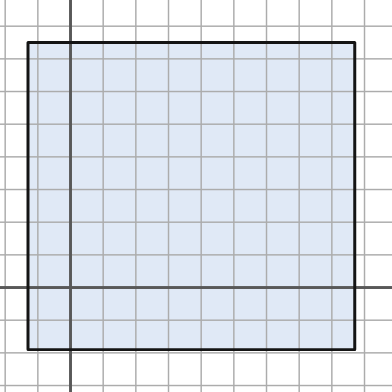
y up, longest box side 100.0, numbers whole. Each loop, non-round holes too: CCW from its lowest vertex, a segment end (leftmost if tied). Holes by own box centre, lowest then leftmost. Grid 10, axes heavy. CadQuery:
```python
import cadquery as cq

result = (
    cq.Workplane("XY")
    .moveTo(-13.0, -19.0)
    .lineTo(87.0, -19.0)
    .lineTo(87.0, 75.0)
    .lineTo(-13.0, 75.0)
    .close()
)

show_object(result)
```